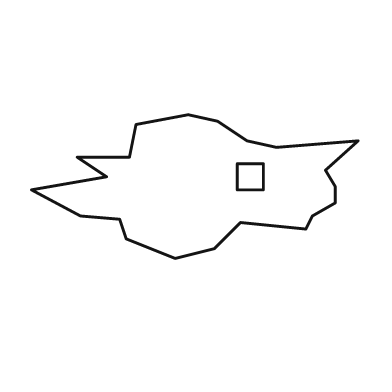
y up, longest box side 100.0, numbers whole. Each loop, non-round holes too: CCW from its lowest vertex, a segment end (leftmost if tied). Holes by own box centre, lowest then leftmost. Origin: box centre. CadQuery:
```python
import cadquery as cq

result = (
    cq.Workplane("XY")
    .moveTo(-6.0, -22.0)
    .lineTo(6.0, -19.0)
    .lineTo(14.0, -11.0)
    .lineTo(34.0, -13.0)
    .lineTo(36.0, -9.0)
    .lineTo(43.0, -5.0)
    .lineTo(43.0, 0.0)
    .lineTo(40.0, 5.0)
    .lineTo(50.0, 14.0)
    .lineTo(25.0, 12.0)
    .lineTo(16.0, 14.0)
    .lineTo(7.0, 20.0)
    .lineTo(-2.0, 22.0)
    .lineTo(-18.0, 19.0)
    .lineTo(-20.0, 9.0)
    .lineTo(-36.0, 9.0)
    .lineTo(-27.0, 3.0)
    .lineTo(-50.0, -1.0)
    .lineTo(-35.0, -9.0)
    .lineTo(-23.0, -10.0)
    .lineTo(-21.0, -16.0)
    .close()
    .moveTo(13.0, -1.0)
    .lineTo(21.0, -1.0)
    .lineTo(21.0, 7.0)
    .lineTo(13.0, 7.0)
    .close()
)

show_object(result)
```